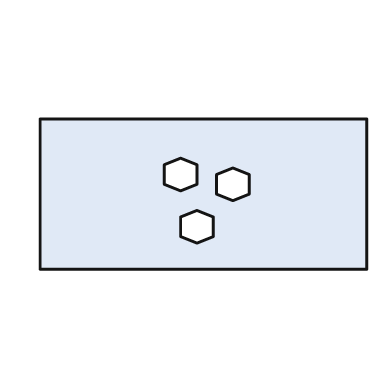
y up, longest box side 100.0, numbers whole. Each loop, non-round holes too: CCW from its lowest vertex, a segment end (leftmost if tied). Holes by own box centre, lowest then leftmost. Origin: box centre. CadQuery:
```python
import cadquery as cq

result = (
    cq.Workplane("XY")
    .moveTo(-50.0, -23.0)
    .lineTo(50.0, -23.0)
    .lineTo(50.0, 23.0)
    .lineTo(-50.0, 23.0)
    .close()
    .moveTo(-2.0, -15.0)
    .lineTo(3.0, -13.0)
    .lineTo(3.0, -7.0)
    .lineTo(-2.0, -5.0)
    .lineTo(-7.0, -7.0)
    .lineTo(-7.0, -13.0)
    .close()
    .moveTo(9.0, -2.0)
    .lineTo(14.0, 0.0)
    .lineTo(14.0, 6.0)
    .lineTo(9.0, 8.0)
    .lineTo(4.0, 6.0)
    .lineTo(4.0, 0.0)
    .close()
    .moveTo(-7.0, 1.0)
    .lineTo(-2.0, 3.0)
    .lineTo(-2.0, 9.0)
    .lineTo(-7.0, 11.0)
    .lineTo(-12.0, 9.0)
    .lineTo(-12.0, 3.0)
    .close()
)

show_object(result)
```